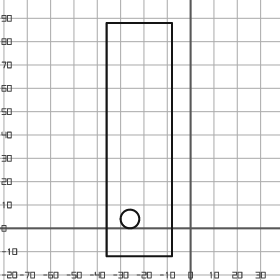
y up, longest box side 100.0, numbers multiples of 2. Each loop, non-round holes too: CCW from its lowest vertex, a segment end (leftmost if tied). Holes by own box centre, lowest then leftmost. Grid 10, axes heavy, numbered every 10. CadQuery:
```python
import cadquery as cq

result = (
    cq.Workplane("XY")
    .moveTo(-36.0, -12.0)
    .lineTo(-8.0, -12.0)
    .lineTo(-8.0, 88.0)
    .lineTo(-36.0, 88.0)
    .close()
    .moveTo(-26.0, 4.0)
    .circle(4.0)
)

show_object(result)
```